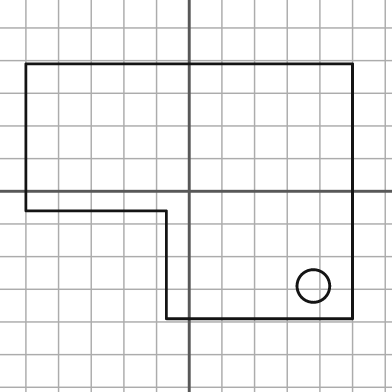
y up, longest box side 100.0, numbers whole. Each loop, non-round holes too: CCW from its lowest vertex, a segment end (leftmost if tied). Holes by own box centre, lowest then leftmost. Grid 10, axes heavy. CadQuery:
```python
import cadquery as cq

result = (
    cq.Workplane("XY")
    .moveTo(-7.0, -39.0)
    .lineTo(50.0, -39.0)
    .lineTo(50.0, 39.0)
    .lineTo(-50.0, 39.0)
    .lineTo(-50.0, -6.0)
    .lineTo(-7.0, -6.0)
    .close()
    .moveTo(38.0, -29.0)
    .circle(5.0)
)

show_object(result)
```